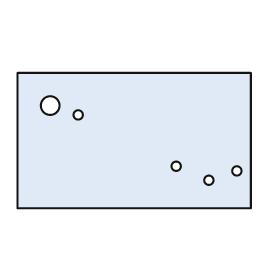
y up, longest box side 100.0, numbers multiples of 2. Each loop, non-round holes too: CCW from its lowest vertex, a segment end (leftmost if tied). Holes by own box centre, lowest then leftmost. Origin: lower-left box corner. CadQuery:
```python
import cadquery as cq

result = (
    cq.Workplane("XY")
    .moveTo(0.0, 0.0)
    .lineTo(100.0, 0.0)
    .lineTo(100.0, 58.0)
    .lineTo(0.0, 58.0)
    .close()
    .moveTo(82.0, 12.0)
    .circle(2.0)
    .moveTo(94.0, 16.0)
    .circle(2.0)
    .moveTo(68.0, 18.0)
    .circle(2.0)
    .moveTo(26.0, 40.0)
    .circle(2.0)
    .moveTo(14.0, 44.0)
    .circle(4.0)
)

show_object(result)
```